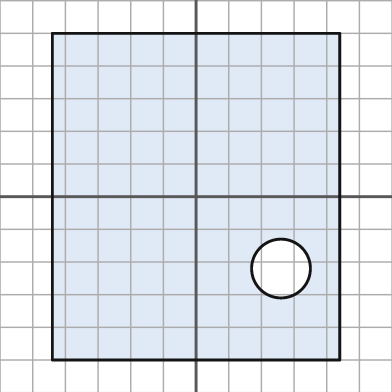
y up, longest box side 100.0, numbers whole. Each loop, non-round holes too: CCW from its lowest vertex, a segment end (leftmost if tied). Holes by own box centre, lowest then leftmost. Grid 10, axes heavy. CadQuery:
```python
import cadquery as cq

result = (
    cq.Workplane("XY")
    .moveTo(-44.0, -50.0)
    .lineTo(44.0, -50.0)
    .lineTo(44.0, 50.0)
    .lineTo(-44.0, 50.0)
    .close()
    .moveTo(26.0, -22.0)
    .circle(9.0)
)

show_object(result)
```